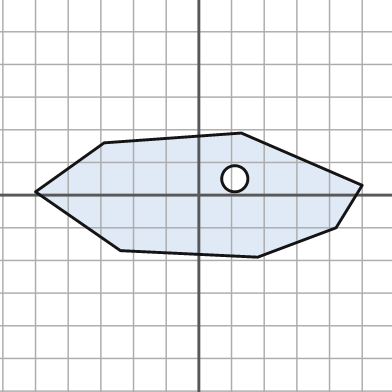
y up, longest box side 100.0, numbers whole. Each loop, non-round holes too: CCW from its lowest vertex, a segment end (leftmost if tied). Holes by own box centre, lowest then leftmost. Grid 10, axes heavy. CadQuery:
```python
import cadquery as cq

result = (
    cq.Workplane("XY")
    .moveTo(18.0, -19.0)
    .lineTo(42.0, -10.0)
    .lineTo(50.0, 3.0)
    .lineTo(13.0, 19.0)
    .lineTo(-29.0, 16.0)
    .lineTo(-50.0, 1.0)
    .lineTo(-24.0, -17.0)
    .close()
    .moveTo(11.0, 5.0)
    .circle(4.0)
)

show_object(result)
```